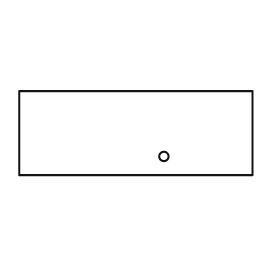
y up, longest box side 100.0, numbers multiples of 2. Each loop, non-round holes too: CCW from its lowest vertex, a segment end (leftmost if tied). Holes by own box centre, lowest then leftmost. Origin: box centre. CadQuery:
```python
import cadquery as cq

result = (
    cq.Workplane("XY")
    .moveTo(-50.0, -18.0)
    .lineTo(50.0, -18.0)
    .lineTo(50.0, 18.0)
    .lineTo(-50.0, 18.0)
    .close()
    .moveTo(12.0, -10.0)
    .circle(2.0)
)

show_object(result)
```